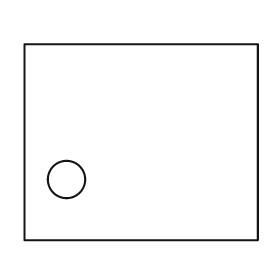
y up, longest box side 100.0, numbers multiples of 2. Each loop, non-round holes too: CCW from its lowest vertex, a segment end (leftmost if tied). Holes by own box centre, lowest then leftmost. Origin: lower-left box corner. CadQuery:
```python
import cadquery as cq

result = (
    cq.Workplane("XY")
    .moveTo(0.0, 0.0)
    .lineTo(100.0, 0.0)
    .lineTo(100.0, 84.0)
    .lineTo(0.0, 84.0)
    .close()
    .moveTo(18.0, 26.0)
    .circle(8.0)
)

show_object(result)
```